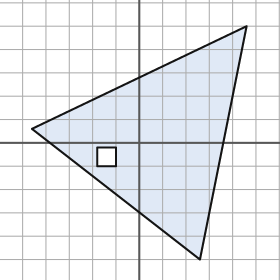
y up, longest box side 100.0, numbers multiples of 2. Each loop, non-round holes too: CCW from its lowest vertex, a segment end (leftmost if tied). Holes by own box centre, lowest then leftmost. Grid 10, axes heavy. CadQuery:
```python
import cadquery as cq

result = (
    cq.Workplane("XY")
    .moveTo(26.0, -50.0)
    .lineTo(46.0, 50.0)
    .lineTo(-46.0, 6.0)
    .close()
    .moveTo(-18.0, -10.0)
    .lineTo(-10.0, -10.0)
    .lineTo(-10.0, -2.0)
    .lineTo(-18.0, -2.0)
    .close()
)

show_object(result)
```